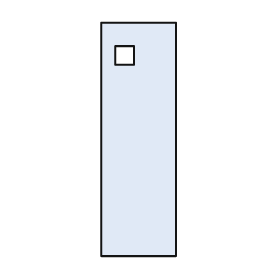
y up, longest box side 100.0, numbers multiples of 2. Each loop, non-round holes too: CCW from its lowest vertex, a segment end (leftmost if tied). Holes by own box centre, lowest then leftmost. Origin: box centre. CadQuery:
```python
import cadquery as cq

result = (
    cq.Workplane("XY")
    .moveTo(-16.0, -50.0)
    .lineTo(16.0, -50.0)
    .lineTo(16.0, 50.0)
    .lineTo(-16.0, 50.0)
    .close()
    .moveTo(-10.0, 32.0)
    .lineTo(-2.0, 32.0)
    .lineTo(-2.0, 40.0)
    .lineTo(-10.0, 40.0)
    .close()
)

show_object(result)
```